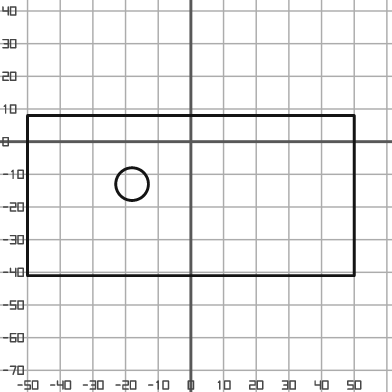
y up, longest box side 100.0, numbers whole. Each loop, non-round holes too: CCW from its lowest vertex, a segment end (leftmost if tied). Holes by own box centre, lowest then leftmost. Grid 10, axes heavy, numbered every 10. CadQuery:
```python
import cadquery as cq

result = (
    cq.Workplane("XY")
    .moveTo(-50.0, -41.0)
    .lineTo(50.0, -41.0)
    .lineTo(50.0, 8.0)
    .lineTo(-50.0, 8.0)
    .close()
    .moveTo(-18.0, -13.0)
    .circle(5.0)
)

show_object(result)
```